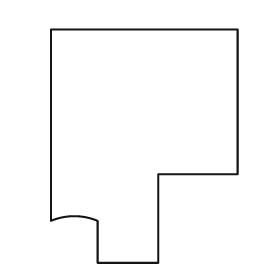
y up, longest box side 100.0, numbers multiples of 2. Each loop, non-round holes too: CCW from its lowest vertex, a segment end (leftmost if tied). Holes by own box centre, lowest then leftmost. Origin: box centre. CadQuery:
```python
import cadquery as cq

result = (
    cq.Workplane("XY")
    .moveTo(-20.0, -50.0)
    .lineTo(6.0, -50.0)
    .lineTo(6.0, -12.0)
    .lineTo(40.0, -12.0)
    .lineTo(40.0, 50.0)
    .lineTo(-40.0, 50.0)
    .lineTo(-40.0, -32.0)
    .threePointArc((-30.0, -30.0), (-20.0, -32.0))
    .close()
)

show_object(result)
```